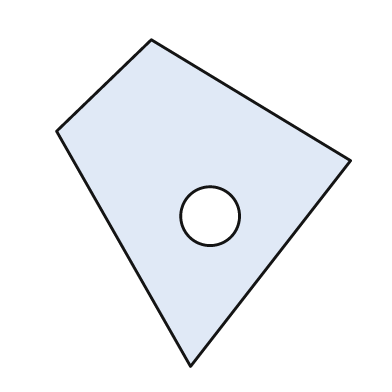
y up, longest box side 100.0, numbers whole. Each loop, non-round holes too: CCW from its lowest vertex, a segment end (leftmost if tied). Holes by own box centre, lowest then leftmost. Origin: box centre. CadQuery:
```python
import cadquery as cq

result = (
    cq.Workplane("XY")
    .moveTo(-4.0, -50.0)
    .lineTo(45.0, 13.0)
    .lineTo(-16.0, 50.0)
    .lineTo(-45.0, 22.0)
    .close()
    .moveTo(2.0, -4.0)
    .circle(9.0)
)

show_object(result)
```